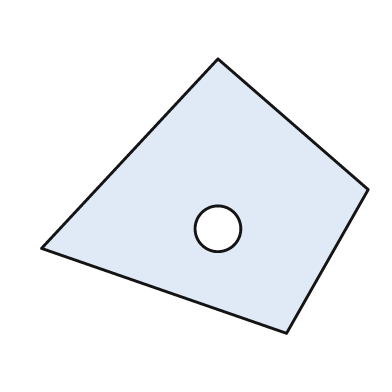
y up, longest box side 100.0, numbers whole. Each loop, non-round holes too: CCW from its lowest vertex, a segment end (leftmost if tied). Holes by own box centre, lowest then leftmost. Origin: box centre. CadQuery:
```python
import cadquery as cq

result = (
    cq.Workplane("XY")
    .moveTo(25.0, -42.0)
    .lineTo(50.0, 2.0)
    .lineTo(4.0, 42.0)
    .lineTo(-50.0, -16.0)
    .close()
    .moveTo(4.0, -10.0)
    .circle(7.0)
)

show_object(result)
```